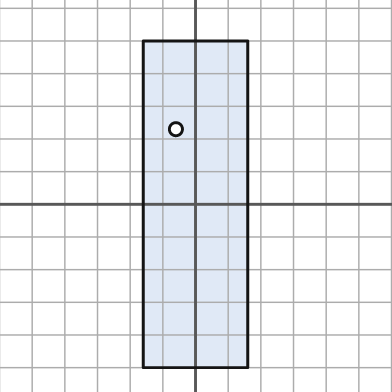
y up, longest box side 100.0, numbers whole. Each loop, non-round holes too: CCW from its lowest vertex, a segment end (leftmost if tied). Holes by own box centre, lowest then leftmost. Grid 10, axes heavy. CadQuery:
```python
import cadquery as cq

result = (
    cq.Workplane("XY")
    .moveTo(-16.0, -50.0)
    .lineTo(16.0, -50.0)
    .lineTo(16.0, 50.0)
    .lineTo(-16.0, 50.0)
    .close()
    .moveTo(-6.0, 23.0)
    .circle(2.0)
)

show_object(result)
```